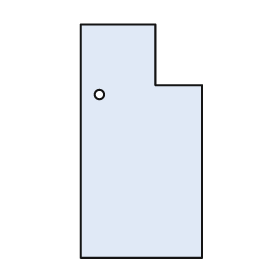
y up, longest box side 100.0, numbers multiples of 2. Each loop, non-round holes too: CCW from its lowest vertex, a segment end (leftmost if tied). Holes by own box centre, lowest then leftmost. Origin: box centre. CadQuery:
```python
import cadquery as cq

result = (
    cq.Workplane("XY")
    .moveTo(-26.0, -50.0)
    .lineTo(26.0, -50.0)
    .lineTo(26.0, 24.0)
    .lineTo(6.0, 24.0)
    .lineTo(6.0, 50.0)
    .lineTo(-26.0, 50.0)
    .close()
    .moveTo(-18.0, 20.0)
    .circle(2.0)
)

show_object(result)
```